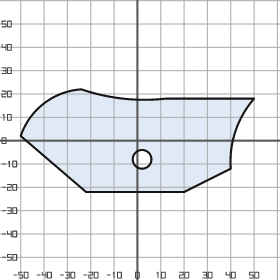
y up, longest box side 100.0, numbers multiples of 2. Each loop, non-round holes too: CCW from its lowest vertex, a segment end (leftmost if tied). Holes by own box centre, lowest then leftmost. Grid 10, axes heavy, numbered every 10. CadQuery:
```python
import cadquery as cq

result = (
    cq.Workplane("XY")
    .moveTo(-22.0, -22.0)
    .lineTo(20.0, -22.0)
    .lineTo(40.0, -12.0)
    .threePointArc((42.0, 4.0), (50.0, 18.0))
    .lineTo(12.0, 18.0)
    .threePointArc((-6.0, 18.0), (-24.0, 22.0))
    .threePointArc((-40.0, 16.0), (-50.0, 2.0))
    .close()
    .moveTo(2.0, -8.0)
    .circle(4.0)
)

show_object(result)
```